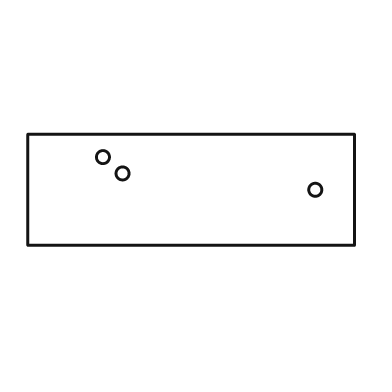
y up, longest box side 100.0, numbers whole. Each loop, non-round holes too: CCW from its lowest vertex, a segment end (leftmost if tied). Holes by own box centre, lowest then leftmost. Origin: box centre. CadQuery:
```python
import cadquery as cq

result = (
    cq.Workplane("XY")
    .moveTo(-50.0, -17.0)
    .lineTo(50.0, -17.0)
    .lineTo(50.0, 17.0)
    .lineTo(-50.0, 17.0)
    .close()
    .moveTo(38.0, 0.0)
    .circle(2.0)
    .moveTo(-21.0, 5.0)
    .circle(2.0)
    .moveTo(-27.0, 10.0)
    .circle(2.0)
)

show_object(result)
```